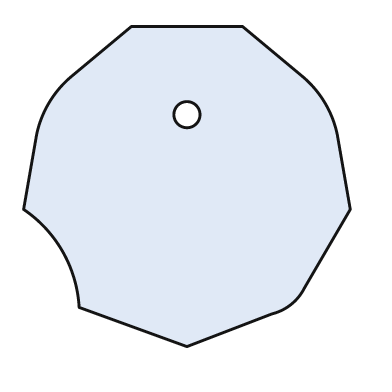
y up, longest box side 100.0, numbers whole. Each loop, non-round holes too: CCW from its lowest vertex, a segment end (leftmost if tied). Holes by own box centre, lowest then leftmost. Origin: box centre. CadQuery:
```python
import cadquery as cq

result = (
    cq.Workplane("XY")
    .moveTo(0.0, -49.0)
    .lineTo(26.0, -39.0)
    .threePointArc((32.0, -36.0), (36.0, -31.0))
    .lineTo(50.0, -7.0)
    .lineTo(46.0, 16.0)
    .threePointArc((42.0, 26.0), (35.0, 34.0))
    .lineTo(17.0, 49.0)
    .lineTo(-17.0, 49.0)
    .lineTo(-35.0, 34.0)
    .threePointArc((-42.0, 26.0), (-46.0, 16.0))
    .lineTo(-50.0, -7.0)
    .threePointArc((-38.0, -20.0), (-33.0, -37.0))
    .close()
    .moveTo(0.0, 22.0)
    .circle(4.0)
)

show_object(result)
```